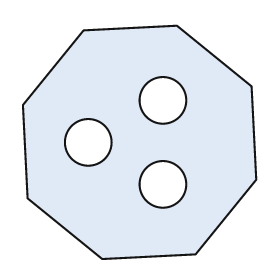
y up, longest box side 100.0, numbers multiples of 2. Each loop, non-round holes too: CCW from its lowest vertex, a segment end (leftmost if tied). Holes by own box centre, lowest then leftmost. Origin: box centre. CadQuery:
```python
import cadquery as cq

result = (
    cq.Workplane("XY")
    .moveTo(-16.0, -50.0)
    .lineTo(24.0, -48.0)
    .lineTo(50.0, -16.0)
    .lineTo(48.0, 24.0)
    .lineTo(16.0, 50.0)
    .lineTo(-24.0, 48.0)
    .lineTo(-50.0, 16.0)
    .lineTo(-48.0, -24.0)
    .close()
    .moveTo(10.0, -18.0)
    .circle(10.0)
    .moveTo(-22.0, 0.0)
    .circle(10.0)
    .moveTo(10.0, 18.0)
    .circle(10.0)
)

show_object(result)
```